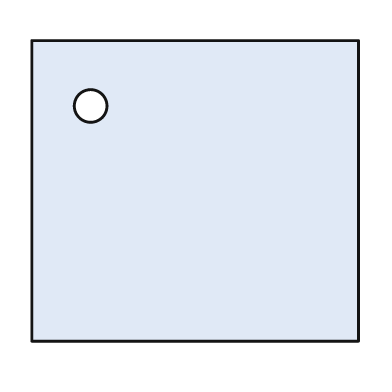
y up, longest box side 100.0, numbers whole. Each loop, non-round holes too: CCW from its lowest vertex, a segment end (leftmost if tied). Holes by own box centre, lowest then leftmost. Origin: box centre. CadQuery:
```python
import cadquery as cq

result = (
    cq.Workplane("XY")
    .moveTo(-50.0, -46.0)
    .lineTo(50.0, -46.0)
    .lineTo(50.0, 46.0)
    .lineTo(-50.0, 46.0)
    .close()
    .moveTo(-32.0, 26.0)
    .circle(5.0)
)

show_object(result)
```